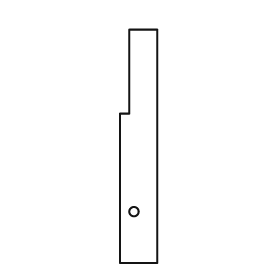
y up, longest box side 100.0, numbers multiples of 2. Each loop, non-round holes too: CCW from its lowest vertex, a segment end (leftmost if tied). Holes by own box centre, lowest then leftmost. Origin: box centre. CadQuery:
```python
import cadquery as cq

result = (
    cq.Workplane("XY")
    .moveTo(-8.0, -50.0)
    .lineTo(8.0, -50.0)
    .lineTo(8.0, 50.0)
    .lineTo(-4.0, 50.0)
    .lineTo(-4.0, 14.0)
    .lineTo(-8.0, 14.0)
    .close()
    .moveTo(-2.0, -28.0)
    .circle(2.0)
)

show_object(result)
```